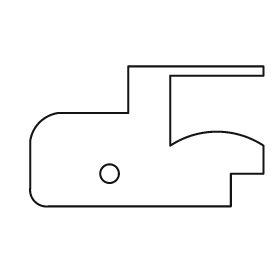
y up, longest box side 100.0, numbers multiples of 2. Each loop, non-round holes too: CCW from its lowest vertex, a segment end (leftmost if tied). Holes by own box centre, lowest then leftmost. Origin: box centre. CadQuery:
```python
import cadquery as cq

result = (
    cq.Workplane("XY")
    .moveTo(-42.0, -30.0)
    .lineTo(36.0, -30.0)
    .lineTo(36.0, -16.0)
    .lineTo(50.0, -16.0)
    .lineTo(50.0, -4.0)
    .threePointArc((30.0, 2.0), (10.0, -4.0))
    .lineTo(10.0, 26.0)
    .lineTo(50.0, 26.0)
    .lineTo(50.0, 30.0)
    .lineTo(-8.0, 30.0)
    .lineTo(-8.0, 10.0)
    .lineTo(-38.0, 10.0)
    .threePointArc((-46.0, 6.0), (-50.0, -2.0))
    .lineTo(-50.0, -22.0)
    .threePointArc((-48.0, -28.0), (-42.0, -30.0))
    .close()
    .moveTo(-16.0, -16.0)
    .circle(4.0)
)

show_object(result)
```